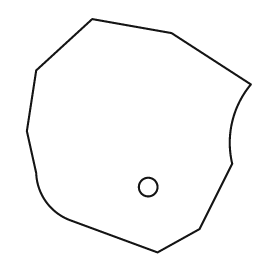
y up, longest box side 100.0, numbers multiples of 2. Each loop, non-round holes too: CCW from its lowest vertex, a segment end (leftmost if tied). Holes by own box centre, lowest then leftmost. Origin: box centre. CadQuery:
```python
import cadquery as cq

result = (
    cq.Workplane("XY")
    .moveTo(8.0, -50.0)
    .lineTo(26.0, -40.0)
    .lineTo(40.0, -12.0)
    .threePointArc((40.0, 6.0), (48.0, 22.0))
    .lineTo(14.0, 44.0)
    .lineTo(-20.0, 50.0)
    .lineTo(-44.0, 28.0)
    .lineTo(-48.0, 2.0)
    .lineTo(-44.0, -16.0)
    .threePointArc((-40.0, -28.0), (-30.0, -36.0))
    .close()
    .moveTo(4.0, -22.0)
    .circle(4.0)
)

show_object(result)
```